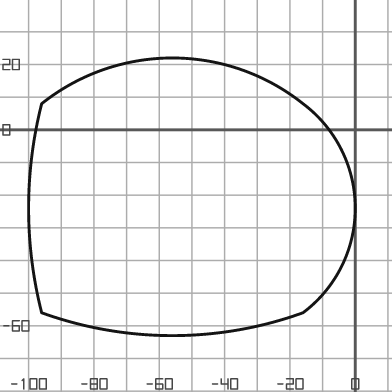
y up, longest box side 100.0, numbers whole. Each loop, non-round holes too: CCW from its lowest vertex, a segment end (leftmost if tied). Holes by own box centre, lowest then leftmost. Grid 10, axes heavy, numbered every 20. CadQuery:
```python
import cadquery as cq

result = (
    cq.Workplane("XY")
    .moveTo(-96.0, -56.0)
    .threePointArc((-56.0, -63.0), (-16.0, -56.0))
    .threePointArc((0.0, -24.0), (-16.0, 8.0))
    .threePointArc((-56.0, 22.0), (-96.0, 8.0))
    .threePointArc((-100.0, -24.0), (-96.0, -56.0))
    .close()
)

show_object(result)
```